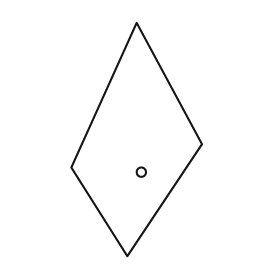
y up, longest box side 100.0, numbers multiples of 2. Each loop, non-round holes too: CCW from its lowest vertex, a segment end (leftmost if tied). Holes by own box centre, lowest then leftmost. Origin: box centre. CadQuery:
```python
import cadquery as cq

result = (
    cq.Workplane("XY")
    .moveTo(-4.0, -50.0)
    .lineTo(28.0, -2.0)
    .lineTo(0.0, 50.0)
    .lineTo(-28.0, -12.0)
    .close()
    .moveTo(2.0, -14.0)
    .circle(2.0)
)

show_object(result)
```